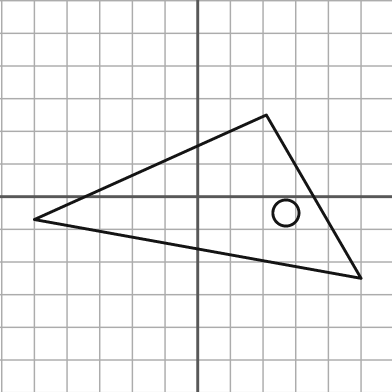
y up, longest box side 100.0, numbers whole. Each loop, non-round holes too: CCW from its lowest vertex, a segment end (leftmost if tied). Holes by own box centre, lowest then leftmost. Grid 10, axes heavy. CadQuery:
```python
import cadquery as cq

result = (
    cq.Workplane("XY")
    .moveTo(50.0, -25.0)
    .lineTo(21.0, 25.0)
    .lineTo(-50.0, -7.0)
    .close()
    .moveTo(27.0, -5.0)
    .circle(4.0)
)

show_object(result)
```